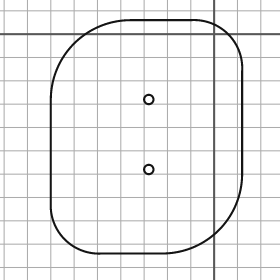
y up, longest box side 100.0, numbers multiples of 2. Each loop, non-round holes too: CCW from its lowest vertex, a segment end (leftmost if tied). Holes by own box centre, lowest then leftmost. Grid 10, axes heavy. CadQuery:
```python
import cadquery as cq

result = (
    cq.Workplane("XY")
    .moveTo(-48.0, -94.0)
    .lineTo(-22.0, -94.0)
    .threePointArc((2.0, -84.0), (12.0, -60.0))
    .lineTo(12.0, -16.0)
    .threePointArc((6.0, 0.0), (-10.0, 6.0))
    .lineTo(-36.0, 6.0)
    .threePointArc((-60.0, -4.0), (-70.0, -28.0))
    .lineTo(-70.0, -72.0)
    .threePointArc((-64.0, -88.0), (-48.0, -94.0))
    .close()
    .moveTo(-28.0, -58.0)
    .circle(2.0)
    .moveTo(-28.0, -28.0)
    .circle(2.0)
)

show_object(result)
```